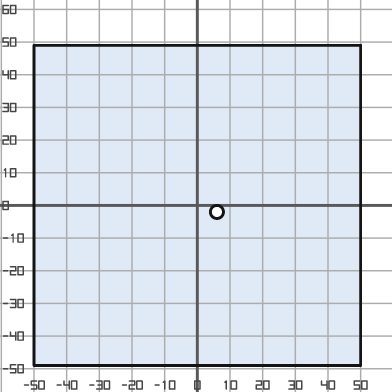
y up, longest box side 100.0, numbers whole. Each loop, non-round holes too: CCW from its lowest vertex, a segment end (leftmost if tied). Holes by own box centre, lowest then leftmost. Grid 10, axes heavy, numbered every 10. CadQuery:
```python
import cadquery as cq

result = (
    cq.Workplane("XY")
    .moveTo(-50.0, -49.0)
    .lineTo(50.0, -49.0)
    .lineTo(50.0, 49.0)
    .lineTo(-50.0, 49.0)
    .close()
    .moveTo(6.0, -2.0)
    .circle(2.0)
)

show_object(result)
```